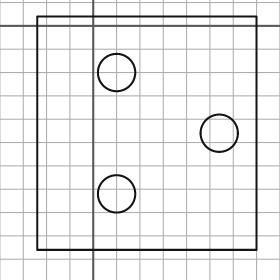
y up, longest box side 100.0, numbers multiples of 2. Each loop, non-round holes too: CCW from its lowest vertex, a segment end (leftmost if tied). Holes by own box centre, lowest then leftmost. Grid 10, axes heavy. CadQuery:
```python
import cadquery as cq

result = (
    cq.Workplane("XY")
    .moveTo(-24.0, -96.0)
    .lineTo(70.0, -96.0)
    .lineTo(70.0, 4.0)
    .lineTo(-24.0, 4.0)
    .close()
    .moveTo(10.0, -72.0)
    .circle(8.0)
    .moveTo(54.0, -46.0)
    .circle(8.0)
    .moveTo(10.0, -20.0)
    .circle(8.0)
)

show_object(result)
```